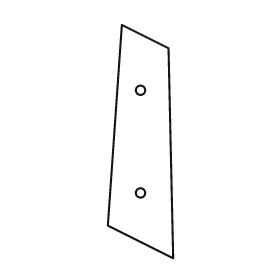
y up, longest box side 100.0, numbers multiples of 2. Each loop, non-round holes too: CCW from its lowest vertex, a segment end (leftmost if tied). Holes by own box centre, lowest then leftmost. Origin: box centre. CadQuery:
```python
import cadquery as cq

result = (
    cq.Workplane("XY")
    .moveTo(14.0, -50.0)
    .lineTo(12.0, 40.0)
    .lineTo(-8.0, 50.0)
    .lineTo(-14.0, -36.0)
    .close()
    .moveTo(0.0, -22.0)
    .circle(2.0)
    .moveTo(0.0, 22.0)
    .circle(2.0)
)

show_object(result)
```